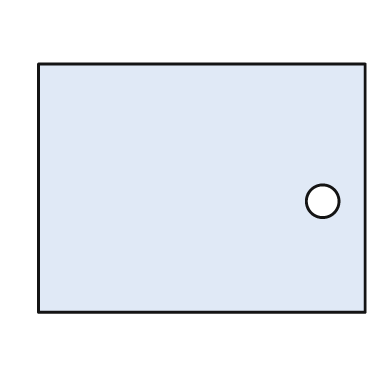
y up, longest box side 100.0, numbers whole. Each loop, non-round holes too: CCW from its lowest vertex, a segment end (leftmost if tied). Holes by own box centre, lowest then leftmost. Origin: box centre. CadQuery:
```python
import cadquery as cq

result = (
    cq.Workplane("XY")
    .moveTo(-50.0, -38.0)
    .lineTo(50.0, -38.0)
    .lineTo(50.0, 38.0)
    .lineTo(-50.0, 38.0)
    .close()
    .moveTo(37.0, -4.0)
    .circle(5.0)
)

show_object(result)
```